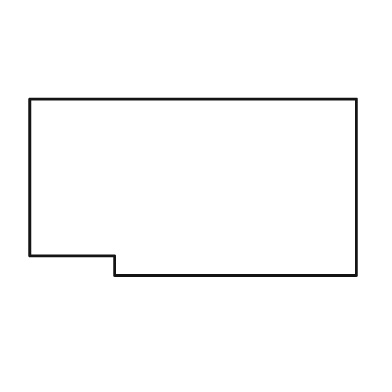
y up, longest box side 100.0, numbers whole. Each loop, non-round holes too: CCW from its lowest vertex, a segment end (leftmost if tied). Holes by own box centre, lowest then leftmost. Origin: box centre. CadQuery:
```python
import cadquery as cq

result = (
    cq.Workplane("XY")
    .moveTo(-24.0, -27.0)
    .lineTo(50.0, -27.0)
    .lineTo(50.0, 27.0)
    .lineTo(-50.0, 27.0)
    .lineTo(-50.0, -21.0)
    .lineTo(-24.0, -21.0)
    .close()
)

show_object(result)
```